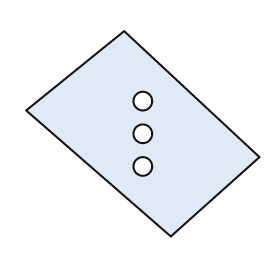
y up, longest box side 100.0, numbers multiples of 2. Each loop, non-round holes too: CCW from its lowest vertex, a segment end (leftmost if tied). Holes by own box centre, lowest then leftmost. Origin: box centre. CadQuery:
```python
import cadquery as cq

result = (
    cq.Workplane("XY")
    .moveTo(12.0, -44.0)
    .lineTo(50.0, -10.0)
    .lineTo(-8.0, 44.0)
    .lineTo(-50.0, 10.0)
    .close()
    .moveTo(0.0, -14.0)
    .circle(4.0)
    .moveTo(0.0, 0.0)
    .circle(4.0)
    .moveTo(0.0, 14.0)
    .circle(4.0)
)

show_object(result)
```